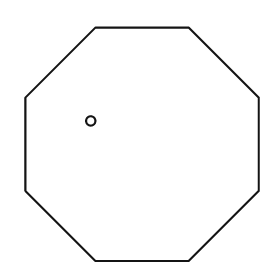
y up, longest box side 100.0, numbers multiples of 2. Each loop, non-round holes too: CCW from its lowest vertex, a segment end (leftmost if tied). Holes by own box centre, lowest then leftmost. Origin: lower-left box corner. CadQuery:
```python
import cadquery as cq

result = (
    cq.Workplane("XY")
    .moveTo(30.0, 0.0)
    .lineTo(70.0, 0.0)
    .lineTo(100.0, 30.0)
    .lineTo(100.0, 70.0)
    .lineTo(70.0, 100.0)
    .lineTo(30.0, 100.0)
    .lineTo(0.0, 70.0)
    .lineTo(0.0, 30.0)
    .close()
    .moveTo(28.0, 60.0)
    .circle(2.0)
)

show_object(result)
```